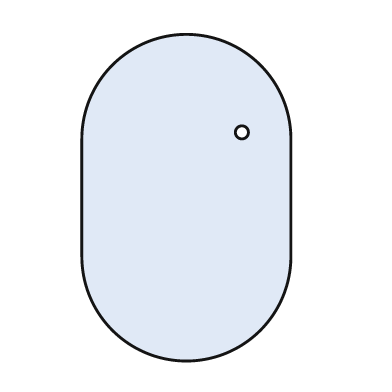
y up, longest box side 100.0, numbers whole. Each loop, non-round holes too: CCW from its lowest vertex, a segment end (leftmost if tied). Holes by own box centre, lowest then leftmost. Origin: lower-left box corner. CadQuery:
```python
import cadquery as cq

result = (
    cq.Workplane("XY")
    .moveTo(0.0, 32.0)
    .threePointArc((32.0, 0.0), (64.0, 32.0))
    .lineTo(64.0, 68.0)
    .threePointArc((32.0, 100.0), (0.0, 68.0))
    .close()
    .moveTo(49.0, 70.0)
    .circle(2.0)
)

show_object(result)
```